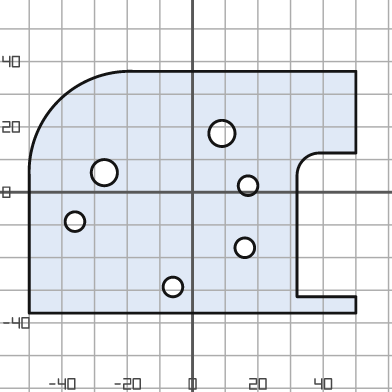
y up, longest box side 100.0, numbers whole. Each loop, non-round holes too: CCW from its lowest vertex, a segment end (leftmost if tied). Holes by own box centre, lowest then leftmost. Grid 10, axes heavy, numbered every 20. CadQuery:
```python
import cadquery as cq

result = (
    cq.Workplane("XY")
    .moveTo(-50.0, -37.0)
    .lineTo(50.0, -37.0)
    .lineTo(50.0, -32.0)
    .lineTo(32.0, -32.0)
    .lineTo(32.0, 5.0)
    .threePointArc((34.0, 10.0), (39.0, 12.0))
    .lineTo(50.0, 12.0)
    .lineTo(50.0, 37.0)
    .lineTo(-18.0, 37.0)
    .threePointArc((-41.0, 28.0), (-50.0, 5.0))
    .close()
    .moveTo(-6.0, -29.0)
    .circle(3.0)
    .moveTo(16.0, -17.0)
    .circle(3.0)
    .moveTo(-36.0, -9.0)
    .circle(3.0)
    .moveTo(17.0, 2.0)
    .circle(3.0)
    .moveTo(-27.0, 6.0)
    .circle(4.0)
    .moveTo(9.0, 18.0)
    .circle(4.0)
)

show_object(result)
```